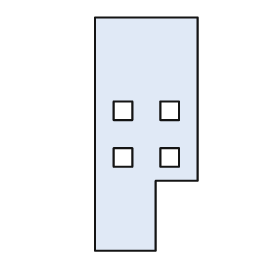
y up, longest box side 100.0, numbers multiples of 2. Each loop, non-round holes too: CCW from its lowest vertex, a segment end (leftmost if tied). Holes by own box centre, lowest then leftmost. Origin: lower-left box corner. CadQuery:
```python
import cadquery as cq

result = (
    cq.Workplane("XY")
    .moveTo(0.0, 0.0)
    .lineTo(26.0, 0.0)
    .lineTo(26.0, 30.0)
    .lineTo(44.0, 30.0)
    .lineTo(44.0, 100.0)
    .lineTo(0.0, 100.0)
    .close()
    .moveTo(8.0, 36.0)
    .lineTo(16.0, 36.0)
    .lineTo(16.0, 44.0)
    .lineTo(8.0, 44.0)
    .close()
    .moveTo(28.0, 36.0)
    .lineTo(36.0, 36.0)
    .lineTo(36.0, 44.0)
    .lineTo(28.0, 44.0)
    .close()
    .moveTo(8.0, 56.0)
    .lineTo(16.0, 56.0)
    .lineTo(16.0, 64.0)
    .lineTo(8.0, 64.0)
    .close()
    .moveTo(28.0, 56.0)
    .lineTo(36.0, 56.0)
    .lineTo(36.0, 64.0)
    .lineTo(28.0, 64.0)
    .close()
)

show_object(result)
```